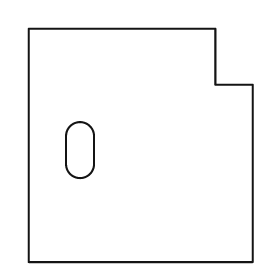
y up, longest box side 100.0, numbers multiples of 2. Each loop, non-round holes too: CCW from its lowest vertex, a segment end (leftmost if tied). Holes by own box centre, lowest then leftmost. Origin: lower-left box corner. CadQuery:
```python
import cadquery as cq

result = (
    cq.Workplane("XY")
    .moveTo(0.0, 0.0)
    .lineTo(96.0, 0.0)
    .lineTo(96.0, 76.0)
    .lineTo(80.0, 76.0)
    .lineTo(80.0, 100.0)
    .lineTo(0.0, 100.0)
    .close()
    .moveTo(16.0, 42.0)
    .threePointArc((22.0, 36.0), (28.0, 42.0))
    .lineTo(28.0, 54.0)
    .threePointArc((22.0, 60.0), (16.0, 54.0))
    .close()
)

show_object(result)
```